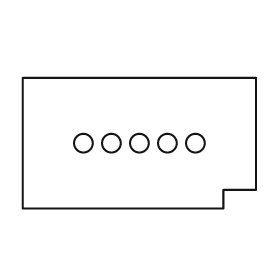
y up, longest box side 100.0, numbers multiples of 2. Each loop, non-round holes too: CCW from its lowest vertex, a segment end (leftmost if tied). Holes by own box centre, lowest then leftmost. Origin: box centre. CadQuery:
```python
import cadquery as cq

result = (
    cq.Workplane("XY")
    .moveTo(-50.0, -28.0)
    .lineTo(36.0, -28.0)
    .lineTo(36.0, -20.0)
    .lineTo(50.0, -20.0)
    .lineTo(50.0, 28.0)
    .lineTo(-50.0, 28.0)
    .close()
    .moveTo(-24.0, 0.0)
    .circle(4.0)
    .moveTo(-12.0, 0.0)
    .circle(4.0)
    .moveTo(0.0, 0.0)
    .circle(4.0)
    .moveTo(12.0, 0.0)
    .circle(4.0)
    .moveTo(24.0, 0.0)
    .circle(4.0)
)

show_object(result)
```